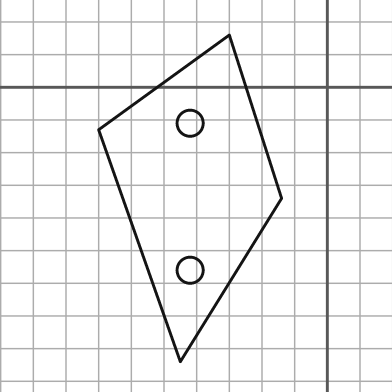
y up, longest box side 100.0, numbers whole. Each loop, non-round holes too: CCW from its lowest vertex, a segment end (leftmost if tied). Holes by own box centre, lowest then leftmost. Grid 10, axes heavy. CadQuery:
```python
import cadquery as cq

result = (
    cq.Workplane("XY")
    .moveTo(-45.0, -84.0)
    .lineTo(-14.0, -34.0)
    .lineTo(-30.0, 16.0)
    .lineTo(-70.0, -13.0)
    .close()
    .moveTo(-42.0, -56.0)
    .circle(4.0)
    .moveTo(-42.0, -11.0)
    .circle(4.0)
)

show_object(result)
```